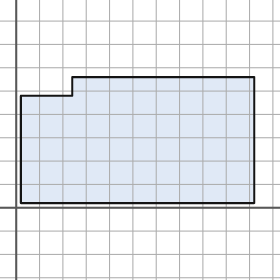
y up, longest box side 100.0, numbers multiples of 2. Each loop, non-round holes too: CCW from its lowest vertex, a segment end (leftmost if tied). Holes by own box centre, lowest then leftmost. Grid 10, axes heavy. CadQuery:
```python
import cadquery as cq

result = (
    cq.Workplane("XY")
    .moveTo(2.0, 2.0)
    .lineTo(102.0, 2.0)
    .lineTo(102.0, 56.0)
    .lineTo(24.0, 56.0)
    .lineTo(24.0, 48.0)
    .lineTo(2.0, 48.0)
    .close()
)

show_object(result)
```